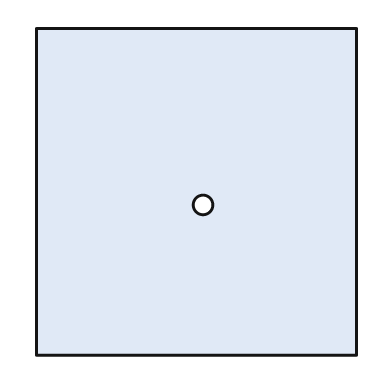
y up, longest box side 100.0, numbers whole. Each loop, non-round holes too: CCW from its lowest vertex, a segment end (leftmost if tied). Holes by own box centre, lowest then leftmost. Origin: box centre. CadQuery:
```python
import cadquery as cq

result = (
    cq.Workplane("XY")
    .moveTo(-49.0, -50.0)
    .lineTo(49.0, -50.0)
    .lineTo(49.0, 50.0)
    .lineTo(-49.0, 50.0)
    .close()
    .moveTo(2.0, -4.0)
    .circle(3.0)
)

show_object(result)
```